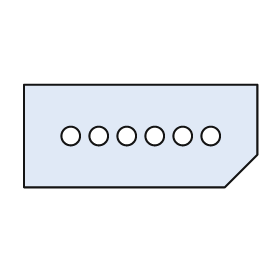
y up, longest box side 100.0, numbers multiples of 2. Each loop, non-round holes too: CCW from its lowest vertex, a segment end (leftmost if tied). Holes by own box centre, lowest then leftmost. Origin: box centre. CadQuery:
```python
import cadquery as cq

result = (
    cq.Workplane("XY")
    .moveTo(-50.0, -22.0)
    .lineTo(36.0, -22.0)
    .lineTo(50.0, -8.0)
    .lineTo(50.0, 22.0)
    .lineTo(-50.0, 22.0)
    .close()
    .moveTo(-30.0, 0.0)
    .circle(4.0)
    .moveTo(-18.0, 0.0)
    .circle(4.0)
    .moveTo(-6.0, 0.0)
    .circle(4.0)
    .moveTo(6.0, 0.0)
    .circle(4.0)
    .moveTo(18.0, 0.0)
    .circle(4.0)
    .moveTo(30.0, 0.0)
    .circle(4.0)
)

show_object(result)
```